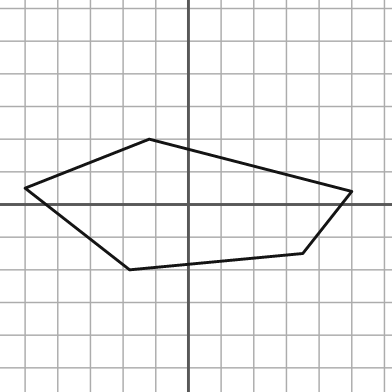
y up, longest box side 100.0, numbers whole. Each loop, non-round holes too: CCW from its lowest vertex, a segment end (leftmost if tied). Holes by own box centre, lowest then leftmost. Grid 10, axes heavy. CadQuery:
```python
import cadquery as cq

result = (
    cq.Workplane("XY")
    .moveTo(-18.0, -20.0)
    .lineTo(35.0, -15.0)
    .lineTo(50.0, 4.0)
    .lineTo(-12.0, 20.0)
    .lineTo(-50.0, 5.0)
    .close()
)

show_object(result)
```